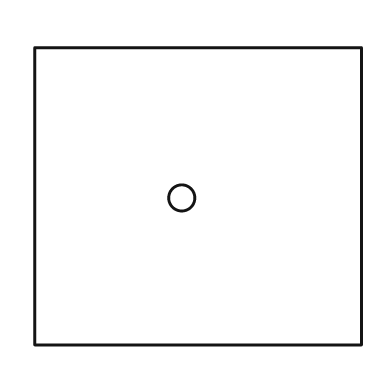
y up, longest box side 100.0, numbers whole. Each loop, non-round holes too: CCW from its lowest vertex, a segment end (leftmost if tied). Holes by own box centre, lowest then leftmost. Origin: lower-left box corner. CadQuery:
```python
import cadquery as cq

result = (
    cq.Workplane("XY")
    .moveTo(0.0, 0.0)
    .lineTo(100.0, 0.0)
    .lineTo(100.0, 91.0)
    .lineTo(0.0, 91.0)
    .close()
    .moveTo(45.0, 45.0)
    .circle(4.0)
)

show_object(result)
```